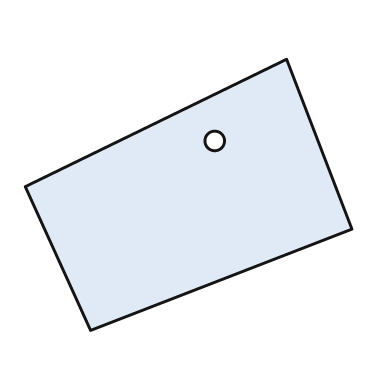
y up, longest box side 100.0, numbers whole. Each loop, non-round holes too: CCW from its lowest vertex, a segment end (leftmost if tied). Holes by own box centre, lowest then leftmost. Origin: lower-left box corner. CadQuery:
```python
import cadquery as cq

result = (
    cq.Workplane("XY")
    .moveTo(20.0, 0.0)
    .lineTo(100.0, 31.0)
    .lineTo(80.0, 83.0)
    .lineTo(0.0, 44.0)
    .close()
    .moveTo(58.0, 58.0)
    .circle(3.0)
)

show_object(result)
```